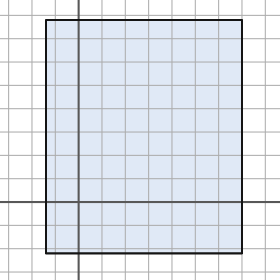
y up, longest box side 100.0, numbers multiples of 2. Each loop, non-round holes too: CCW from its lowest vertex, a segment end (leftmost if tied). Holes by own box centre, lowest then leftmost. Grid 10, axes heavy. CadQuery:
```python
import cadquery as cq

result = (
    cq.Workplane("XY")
    .moveTo(-14.0, -22.0)
    .lineTo(70.0, -22.0)
    .lineTo(70.0, 78.0)
    .lineTo(-14.0, 78.0)
    .close()
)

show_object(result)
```